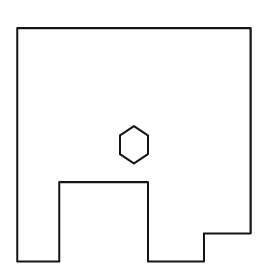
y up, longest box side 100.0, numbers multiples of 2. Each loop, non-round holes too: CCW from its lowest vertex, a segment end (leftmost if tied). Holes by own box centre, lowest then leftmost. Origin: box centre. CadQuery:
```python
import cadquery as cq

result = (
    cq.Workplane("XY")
    .moveTo(-50.0, -50.0)
    .lineTo(-32.0, -50.0)
    .lineTo(-32.0, -16.0)
    .lineTo(6.0, -16.0)
    .lineTo(6.0, -50.0)
    .lineTo(30.0, -50.0)
    .lineTo(30.0, -38.0)
    .lineTo(50.0, -38.0)
    .lineTo(50.0, 50.0)
    .lineTo(-50.0, 50.0)
    .close()
    .moveTo(0.0, -8.0)
    .lineTo(6.0, -4.0)
    .lineTo(6.0, 4.0)
    .lineTo(0.0, 8.0)
    .lineTo(-6.0, 4.0)
    .lineTo(-6.0, -4.0)
    .close()
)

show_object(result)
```